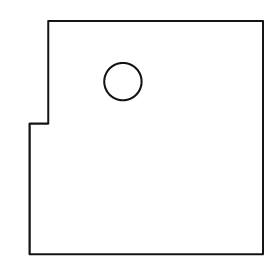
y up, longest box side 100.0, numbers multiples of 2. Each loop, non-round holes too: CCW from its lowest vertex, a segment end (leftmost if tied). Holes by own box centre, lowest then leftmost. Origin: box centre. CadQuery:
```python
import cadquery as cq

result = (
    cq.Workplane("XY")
    .moveTo(-50.0, -50.0)
    .lineTo(50.0, -50.0)
    .lineTo(50.0, 50.0)
    .lineTo(-42.0, 50.0)
    .lineTo(-42.0, 6.0)
    .lineTo(-50.0, 6.0)
    .close()
    .moveTo(-10.0, 24.0)
    .circle(8.0)
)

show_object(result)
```